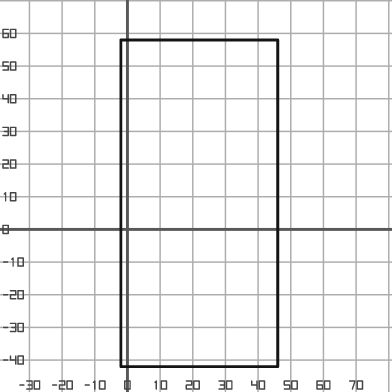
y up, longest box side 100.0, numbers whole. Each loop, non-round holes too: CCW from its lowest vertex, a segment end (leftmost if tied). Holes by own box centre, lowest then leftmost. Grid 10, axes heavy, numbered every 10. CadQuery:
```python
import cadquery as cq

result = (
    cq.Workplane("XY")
    .moveTo(-2.0, -42.0)
    .lineTo(46.0, -42.0)
    .lineTo(46.0, 58.0)
    .lineTo(-2.0, 58.0)
    .close()
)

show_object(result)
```